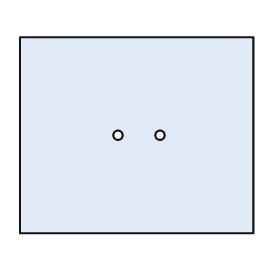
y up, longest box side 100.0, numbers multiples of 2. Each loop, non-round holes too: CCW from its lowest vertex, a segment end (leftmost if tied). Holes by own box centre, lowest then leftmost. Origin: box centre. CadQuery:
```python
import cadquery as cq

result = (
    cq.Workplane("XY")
    .moveTo(-50.0, -42.0)
    .lineTo(50.0, -42.0)
    .lineTo(50.0, 42.0)
    .lineTo(-50.0, 42.0)
    .close()
    .moveTo(-8.0, 0.0)
    .circle(2.0)
    .moveTo(10.0, 0.0)
    .circle(2.0)
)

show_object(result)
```